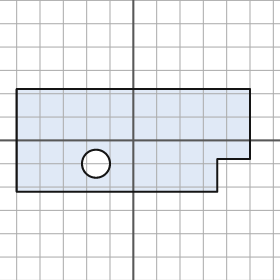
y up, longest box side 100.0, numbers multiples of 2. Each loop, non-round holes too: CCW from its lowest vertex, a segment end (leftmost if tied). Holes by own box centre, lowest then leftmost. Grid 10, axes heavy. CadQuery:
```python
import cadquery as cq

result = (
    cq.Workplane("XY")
    .moveTo(-50.0, -22.0)
    .lineTo(36.0, -22.0)
    .lineTo(36.0, -8.0)
    .lineTo(50.0, -8.0)
    .lineTo(50.0, 22.0)
    .lineTo(-50.0, 22.0)
    .close()
    .moveTo(-16.0, -10.0)
    .circle(6.0)
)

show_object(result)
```